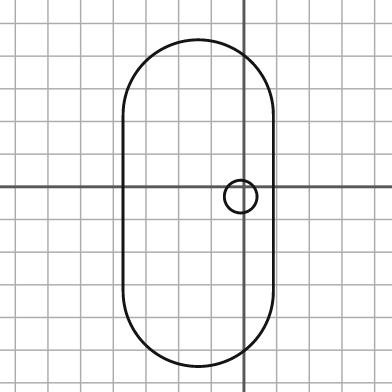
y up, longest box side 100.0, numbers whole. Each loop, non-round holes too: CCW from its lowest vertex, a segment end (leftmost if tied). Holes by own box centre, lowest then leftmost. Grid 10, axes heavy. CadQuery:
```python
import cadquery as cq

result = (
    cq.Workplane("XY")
    .moveTo(-37.0, -32.0)
    .threePointArc((-14.0, -55.0), (9.0, -32.0))
    .lineTo(9.0, 22.0)
    .threePointArc((-14.0, 45.0), (-37.0, 22.0))
    .close()
    .moveTo(-1.0, -3.0)
    .circle(5.0)
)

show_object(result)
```